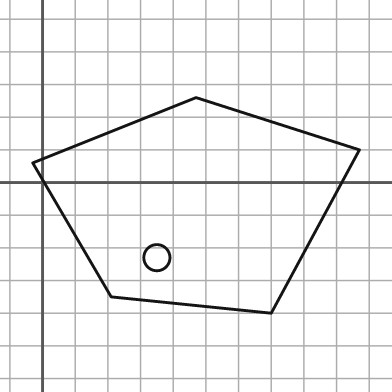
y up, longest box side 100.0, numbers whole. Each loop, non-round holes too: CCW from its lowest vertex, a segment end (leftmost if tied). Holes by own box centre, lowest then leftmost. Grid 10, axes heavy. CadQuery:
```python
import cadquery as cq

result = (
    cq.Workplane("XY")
    .moveTo(70.0, -40.0)
    .lineTo(97.0, 10.0)
    .lineTo(47.0, 26.0)
    .lineTo(-3.0, 6.0)
    .lineTo(21.0, -35.0)
    .close()
    .moveTo(35.0, -23.0)
    .circle(4.0)
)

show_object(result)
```